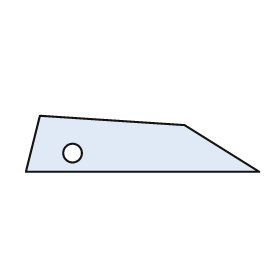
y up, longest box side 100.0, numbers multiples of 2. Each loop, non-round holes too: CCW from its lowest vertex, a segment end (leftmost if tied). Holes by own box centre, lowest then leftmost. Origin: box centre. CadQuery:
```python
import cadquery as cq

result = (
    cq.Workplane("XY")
    .moveTo(-50.0, -12.0)
    .lineTo(50.0, -12.0)
    .lineTo(18.0, 8.0)
    .lineTo(-44.0, 12.0)
    .close()
    .moveTo(-30.0, -4.0)
    .circle(4.0)
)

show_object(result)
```